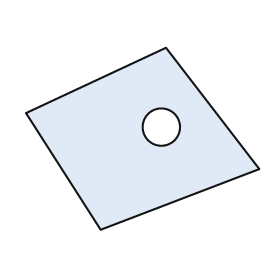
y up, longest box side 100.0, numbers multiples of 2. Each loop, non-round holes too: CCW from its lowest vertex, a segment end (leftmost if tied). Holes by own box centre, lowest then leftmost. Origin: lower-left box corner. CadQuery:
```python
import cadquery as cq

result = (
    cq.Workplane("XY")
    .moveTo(32.0, 0.0)
    .lineTo(100.0, 26.0)
    .lineTo(60.0, 78.0)
    .lineTo(0.0, 50.0)
    .close()
    .moveTo(58.0, 44.0)
    .circle(8.0)
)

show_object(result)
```